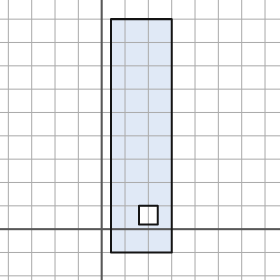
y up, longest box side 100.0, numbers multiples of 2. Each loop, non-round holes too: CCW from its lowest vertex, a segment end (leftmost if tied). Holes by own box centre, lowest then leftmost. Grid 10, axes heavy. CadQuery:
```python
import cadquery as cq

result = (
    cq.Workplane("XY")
    .moveTo(4.0, -10.0)
    .lineTo(30.0, -10.0)
    .lineTo(30.0, 90.0)
    .lineTo(4.0, 90.0)
    .close()
    .moveTo(16.0, 2.0)
    .lineTo(24.0, 2.0)
    .lineTo(24.0, 10.0)
    .lineTo(16.0, 10.0)
    .close()
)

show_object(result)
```